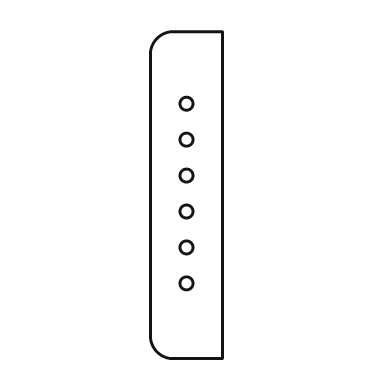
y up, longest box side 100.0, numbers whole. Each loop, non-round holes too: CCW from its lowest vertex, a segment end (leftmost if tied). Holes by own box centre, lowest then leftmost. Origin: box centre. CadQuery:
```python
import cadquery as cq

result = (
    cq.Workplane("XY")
    .moveTo(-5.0, -50.0)
    .lineTo(11.0, -50.0)
    .lineTo(11.0, 50.0)
    .lineTo(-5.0, 50.0)
    .threePointArc((-9.0, 48.0), (-11.0, 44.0))
    .lineTo(-11.0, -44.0)
    .threePointArc((-9.0, -48.0), (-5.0, -50.0))
    .close()
    .moveTo(0.0, -27.0)
    .circle(2.0)
    .moveTo(0.0, -16.0)
    .circle(2.0)
    .moveTo(0.0, -5.0)
    .circle(2.0)
    .moveTo(0.0, 6.0)
    .circle(2.0)
    .moveTo(0.0, 17.0)
    .circle(2.0)
    .moveTo(0.0, 28.0)
    .circle(2.0)
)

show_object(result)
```